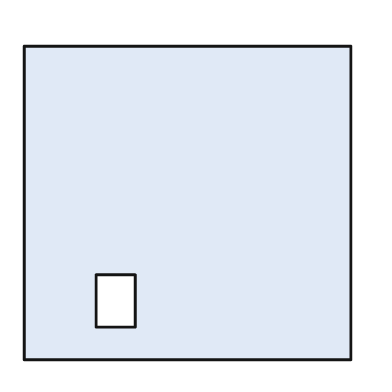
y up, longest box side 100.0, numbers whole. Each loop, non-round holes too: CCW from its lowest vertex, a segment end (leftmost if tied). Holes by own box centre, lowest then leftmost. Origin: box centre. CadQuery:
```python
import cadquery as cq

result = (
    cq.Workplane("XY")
    .moveTo(-50.0, -48.0)
    .lineTo(50.0, -48.0)
    .lineTo(50.0, 48.0)
    .lineTo(-50.0, 48.0)
    .close()
    .moveTo(-28.0, -38.0)
    .lineTo(-16.0, -38.0)
    .lineTo(-16.0, -22.0)
    .lineTo(-28.0, -22.0)
    .close()
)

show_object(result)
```